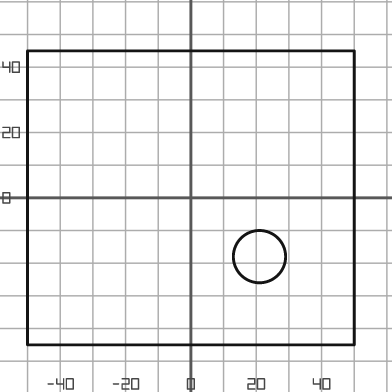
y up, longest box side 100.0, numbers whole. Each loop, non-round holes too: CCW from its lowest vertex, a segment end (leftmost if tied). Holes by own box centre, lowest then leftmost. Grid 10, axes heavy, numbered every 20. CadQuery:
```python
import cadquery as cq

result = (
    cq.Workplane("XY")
    .moveTo(-50.0, -45.0)
    .lineTo(50.0, -45.0)
    .lineTo(50.0, 45.0)
    .lineTo(-50.0, 45.0)
    .close()
    .moveTo(21.0, -18.0)
    .circle(8.0)
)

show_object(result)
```